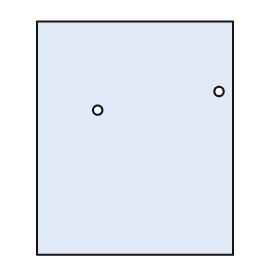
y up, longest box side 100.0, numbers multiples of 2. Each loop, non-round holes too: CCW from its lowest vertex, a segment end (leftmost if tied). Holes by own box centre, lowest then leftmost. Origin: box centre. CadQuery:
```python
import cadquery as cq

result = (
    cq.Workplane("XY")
    .moveTo(-42.0, -50.0)
    .lineTo(42.0, -50.0)
    .lineTo(42.0, 50.0)
    .lineTo(-42.0, 50.0)
    .close()
    .moveTo(-16.0, 12.0)
    .circle(2.0)
    .moveTo(36.0, 20.0)
    .circle(2.0)
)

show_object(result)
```